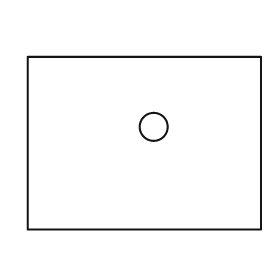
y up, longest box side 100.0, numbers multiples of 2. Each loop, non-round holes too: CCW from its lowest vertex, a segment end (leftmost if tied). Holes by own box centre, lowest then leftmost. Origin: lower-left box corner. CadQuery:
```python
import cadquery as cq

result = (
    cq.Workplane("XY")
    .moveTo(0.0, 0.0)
    .lineTo(100.0, 0.0)
    .lineTo(100.0, 74.0)
    .lineTo(0.0, 74.0)
    .close()
    .moveTo(54.0, 44.0)
    .circle(6.0)
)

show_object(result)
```